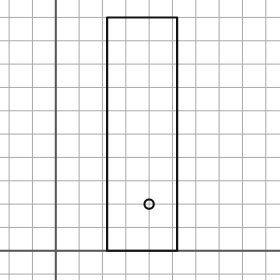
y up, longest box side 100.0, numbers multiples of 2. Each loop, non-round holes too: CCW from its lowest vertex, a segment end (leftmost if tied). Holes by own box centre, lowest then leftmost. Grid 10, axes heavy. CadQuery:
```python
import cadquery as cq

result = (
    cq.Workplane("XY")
    .moveTo(22.0, 0.0)
    .lineTo(52.0, 0.0)
    .lineTo(52.0, 100.0)
    .lineTo(22.0, 100.0)
    .close()
    .moveTo(40.0, 20.0)
    .circle(2.0)
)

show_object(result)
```